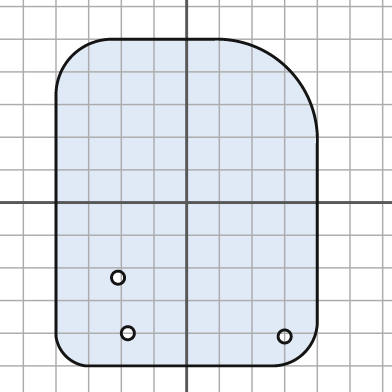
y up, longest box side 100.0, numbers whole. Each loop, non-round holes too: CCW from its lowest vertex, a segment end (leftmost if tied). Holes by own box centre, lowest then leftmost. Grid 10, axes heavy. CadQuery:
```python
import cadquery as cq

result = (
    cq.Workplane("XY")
    .moveTo(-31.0, -50.0)
    .lineTo(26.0, -50.0)
    .threePointArc((36.0, -46.0), (40.0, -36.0))
    .lineTo(40.0, 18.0)
    .threePointArc((31.0, 41.0), (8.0, 50.0))
    .lineTo(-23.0, 50.0)
    .threePointArc((-35.0, 45.0), (-40.0, 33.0))
    .lineTo(-40.0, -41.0)
    .threePointArc((-37.0, -47.0), (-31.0, -50.0))
    .close()
    .moveTo(30.0, -41.0)
    .circle(2.0)
    .moveTo(-18.0, -40.0)
    .circle(2.0)
    .moveTo(-21.0, -23.0)
    .circle(2.0)
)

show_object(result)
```